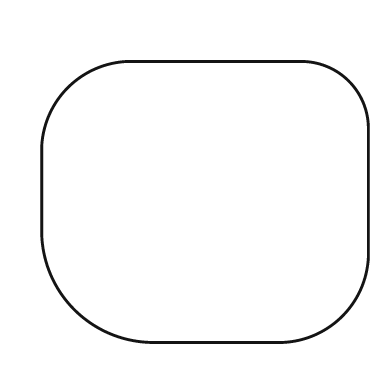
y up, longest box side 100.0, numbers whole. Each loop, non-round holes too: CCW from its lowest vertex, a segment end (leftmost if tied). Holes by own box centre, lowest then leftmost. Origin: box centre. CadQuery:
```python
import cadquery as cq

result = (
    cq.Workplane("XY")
    .moveTo(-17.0, -43.0)
    .lineTo(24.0, -43.0)
    .threePointArc((42.0, -35.0), (50.0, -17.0))
    .lineTo(50.0, 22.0)
    .threePointArc((44.0, 37.0), (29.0, 43.0))
    .lineTo(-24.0, 43.0)
    .threePointArc((-42.0, 35.0), (-50.0, 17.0))
    .lineTo(-50.0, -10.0)
    .threePointArc((-40.0, -33.0), (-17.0, -43.0))
    .close()
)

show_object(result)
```